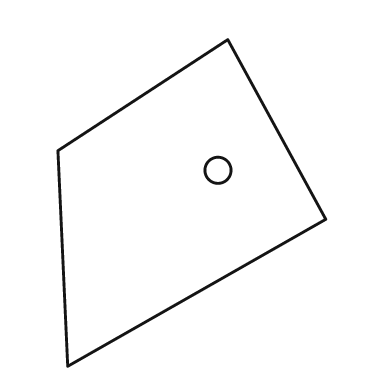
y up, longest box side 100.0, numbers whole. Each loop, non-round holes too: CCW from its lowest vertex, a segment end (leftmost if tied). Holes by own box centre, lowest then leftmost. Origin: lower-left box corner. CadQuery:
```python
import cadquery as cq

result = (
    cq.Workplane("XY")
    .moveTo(3.0, 0.0)
    .lineTo(82.0, 45.0)
    .lineTo(52.0, 100.0)
    .lineTo(0.0, 66.0)
    .close()
    .moveTo(49.0, 60.0)
    .circle(4.0)
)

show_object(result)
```